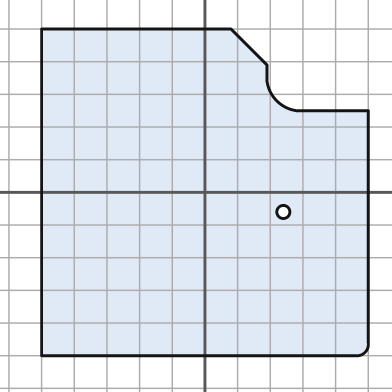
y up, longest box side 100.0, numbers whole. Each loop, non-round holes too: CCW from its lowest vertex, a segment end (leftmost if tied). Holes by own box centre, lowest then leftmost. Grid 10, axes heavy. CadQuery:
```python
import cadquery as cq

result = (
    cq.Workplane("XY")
    .moveTo(-50.0, -50.0)
    .lineTo(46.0, -50.0)
    .threePointArc((49.0, -49.0), (50.0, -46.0))
    .lineTo(50.0, 25.0)
    .lineTo(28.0, 25.0)
    .threePointArc((22.0, 28.0), (19.0, 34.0))
    .lineTo(19.0, 39.0)
    .lineTo(8.0, 50.0)
    .lineTo(-50.0, 50.0)
    .close()
    .moveTo(24.0, -6.0)
    .circle(2.0)
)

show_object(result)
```